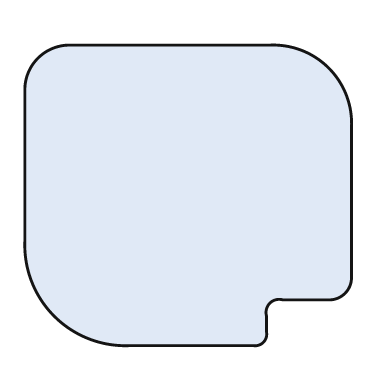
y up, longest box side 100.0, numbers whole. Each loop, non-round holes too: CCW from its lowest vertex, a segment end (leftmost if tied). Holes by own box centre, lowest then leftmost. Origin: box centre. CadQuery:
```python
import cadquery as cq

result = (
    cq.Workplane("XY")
    .moveTo(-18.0, -46.0)
    .lineTo(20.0, -46.0)
    .threePointArc((23.0, -45.0), (24.0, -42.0))
    .lineTo(24.0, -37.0)
    .threePointArc((25.0, -33.0), (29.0, -32.0))
    .lineTo(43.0, -32.0)
    .threePointArc((48.0, -30.0), (50.0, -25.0))
    .lineTo(50.0, 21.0)
    .threePointArc((43.0, 39.0), (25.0, 46.0))
    .lineTo(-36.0, 46.0)
    .threePointArc((-46.0, 42.0), (-50.0, 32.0))
    .lineTo(-50.0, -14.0)
    .threePointArc((-41.0, -37.0), (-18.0, -46.0))
    .close()
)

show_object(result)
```